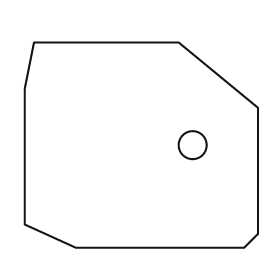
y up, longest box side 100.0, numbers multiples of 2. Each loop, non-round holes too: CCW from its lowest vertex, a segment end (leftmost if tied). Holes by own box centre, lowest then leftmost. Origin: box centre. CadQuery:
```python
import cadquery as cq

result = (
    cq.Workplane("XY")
    .moveTo(-28.0, -44.0)
    .lineTo(44.0, -44.0)
    .lineTo(50.0, -38.0)
    .lineTo(50.0, 16.0)
    .lineTo(16.0, 44.0)
    .lineTo(-46.0, 44.0)
    .lineTo(-50.0, 24.0)
    .lineTo(-50.0, -34.0)
    .close()
    .moveTo(22.0, 0.0)
    .circle(6.0)
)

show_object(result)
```